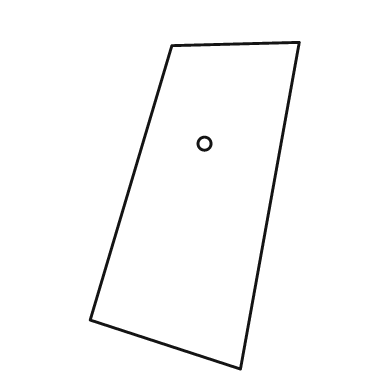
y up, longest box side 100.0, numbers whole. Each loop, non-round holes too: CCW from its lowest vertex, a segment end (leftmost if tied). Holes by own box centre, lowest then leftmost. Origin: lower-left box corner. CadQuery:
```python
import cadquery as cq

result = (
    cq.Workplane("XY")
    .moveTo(46.0, 0.0)
    .lineTo(64.0, 100.0)
    .lineTo(25.0, 99.0)
    .lineTo(0.0, 15.0)
    .close()
    .moveTo(35.0, 69.0)
    .circle(2.0)
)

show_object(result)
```